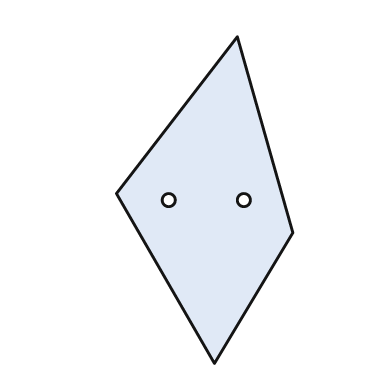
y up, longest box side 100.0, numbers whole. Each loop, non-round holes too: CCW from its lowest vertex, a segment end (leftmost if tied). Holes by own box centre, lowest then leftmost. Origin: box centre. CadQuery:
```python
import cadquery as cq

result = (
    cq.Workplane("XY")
    .moveTo(3.0, -50.0)
    .lineTo(27.0, -10.0)
    .lineTo(10.0, 50.0)
    .lineTo(-27.0, 2.0)
    .close()
    .moveTo(-11.0, 0.0)
    .circle(2.0)
    .moveTo(12.0, 0.0)
    .circle(2.0)
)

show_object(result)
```